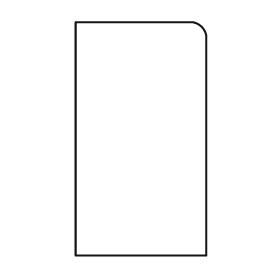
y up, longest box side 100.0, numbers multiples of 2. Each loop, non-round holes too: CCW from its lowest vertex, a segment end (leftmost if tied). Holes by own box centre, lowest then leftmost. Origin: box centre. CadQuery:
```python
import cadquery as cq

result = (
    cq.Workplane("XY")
    .moveTo(-28.0, -50.0)
    .lineTo(28.0, -50.0)
    .lineTo(28.0, 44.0)
    .threePointArc((26.0, 48.0), (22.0, 50.0))
    .lineTo(-28.0, 50.0)
    .close()
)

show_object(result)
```